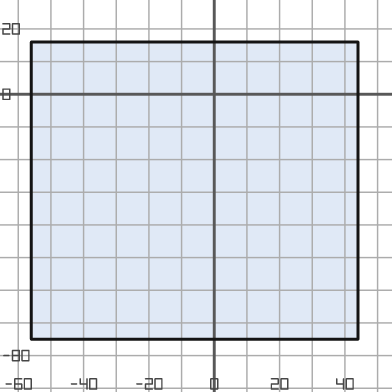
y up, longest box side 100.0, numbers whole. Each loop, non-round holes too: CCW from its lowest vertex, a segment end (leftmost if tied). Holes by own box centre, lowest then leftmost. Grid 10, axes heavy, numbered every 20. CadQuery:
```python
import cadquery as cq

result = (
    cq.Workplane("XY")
    .moveTo(-56.0, -75.0)
    .lineTo(44.0, -75.0)
    .lineTo(44.0, 16.0)
    .lineTo(-56.0, 16.0)
    .close()
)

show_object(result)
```